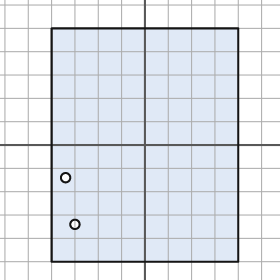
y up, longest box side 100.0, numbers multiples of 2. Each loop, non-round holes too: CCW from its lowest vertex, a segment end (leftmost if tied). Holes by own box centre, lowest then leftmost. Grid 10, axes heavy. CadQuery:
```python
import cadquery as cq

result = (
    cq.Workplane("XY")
    .moveTo(-40.0, -50.0)
    .lineTo(40.0, -50.0)
    .lineTo(40.0, 50.0)
    .lineTo(-40.0, 50.0)
    .close()
    .moveTo(-30.0, -34.0)
    .circle(2.0)
    .moveTo(-34.0, -14.0)
    .circle(2.0)
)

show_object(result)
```